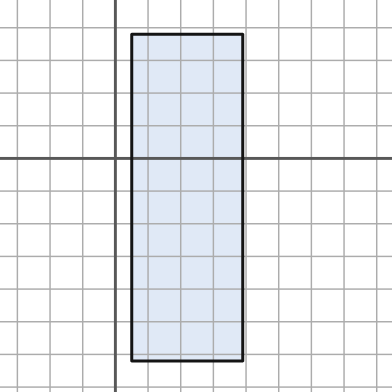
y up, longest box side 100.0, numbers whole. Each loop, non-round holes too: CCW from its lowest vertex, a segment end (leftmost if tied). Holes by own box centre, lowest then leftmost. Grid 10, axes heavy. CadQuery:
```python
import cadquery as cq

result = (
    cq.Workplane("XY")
    .moveTo(5.0, -62.0)
    .lineTo(39.0, -62.0)
    .lineTo(39.0, 38.0)
    .lineTo(5.0, 38.0)
    .close()
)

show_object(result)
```